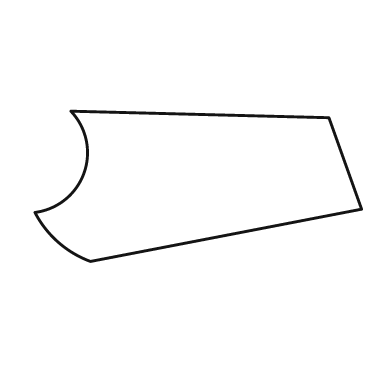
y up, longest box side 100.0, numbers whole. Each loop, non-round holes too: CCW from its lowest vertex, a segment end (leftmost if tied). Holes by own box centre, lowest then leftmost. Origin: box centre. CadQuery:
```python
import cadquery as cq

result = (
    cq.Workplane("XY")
    .moveTo(-33.0, -23.0)
    .lineTo(50.0, -7.0)
    .lineTo(40.0, 21.0)
    .lineTo(-39.0, 23.0)
    .threePointArc((-35.0, 4.0), (-50.0, -8.0))
    .threePointArc((-43.0, -17.0), (-33.0, -23.0))
    .close()
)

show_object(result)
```